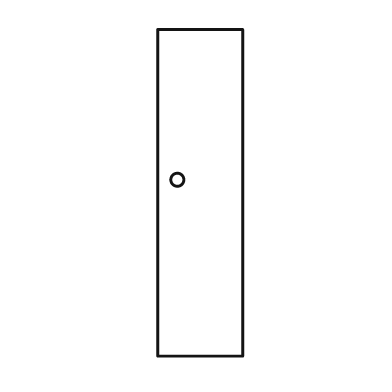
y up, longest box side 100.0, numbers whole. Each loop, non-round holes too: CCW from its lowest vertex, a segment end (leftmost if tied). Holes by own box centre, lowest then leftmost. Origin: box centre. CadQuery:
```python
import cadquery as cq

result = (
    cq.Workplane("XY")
    .moveTo(-13.0, -50.0)
    .lineTo(13.0, -50.0)
    .lineTo(13.0, 50.0)
    .lineTo(-13.0, 50.0)
    .close()
    .moveTo(-7.0, 4.0)
    .circle(2.0)
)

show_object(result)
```